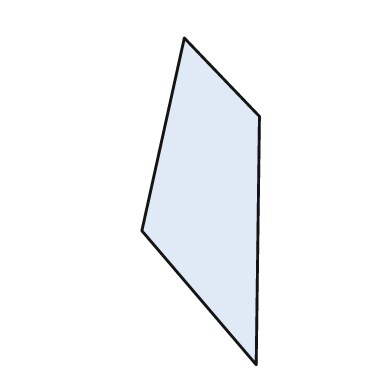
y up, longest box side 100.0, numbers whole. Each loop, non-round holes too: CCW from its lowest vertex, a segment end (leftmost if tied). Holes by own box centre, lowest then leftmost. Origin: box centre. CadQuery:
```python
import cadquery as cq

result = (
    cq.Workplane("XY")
    .moveTo(17.0, -50.0)
    .lineTo(18.0, 26.0)
    .lineTo(-5.0, 50.0)
    .lineTo(-18.0, -9.0)
    .close()
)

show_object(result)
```